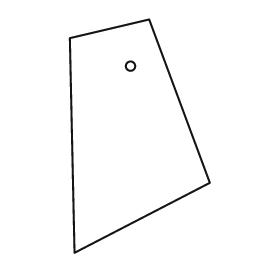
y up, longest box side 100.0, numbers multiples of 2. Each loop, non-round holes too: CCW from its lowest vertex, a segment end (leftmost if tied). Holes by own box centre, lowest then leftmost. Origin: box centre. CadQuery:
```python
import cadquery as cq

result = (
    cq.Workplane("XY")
    .moveTo(-28.0, -50.0)
    .lineTo(30.0, -20.0)
    .lineTo(4.0, 50.0)
    .lineTo(-30.0, 42.0)
    .close()
    .moveTo(-4.0, 30.0)
    .circle(2.0)
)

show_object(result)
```